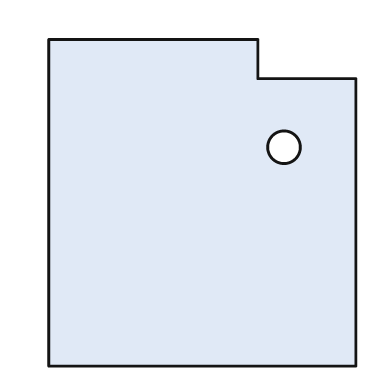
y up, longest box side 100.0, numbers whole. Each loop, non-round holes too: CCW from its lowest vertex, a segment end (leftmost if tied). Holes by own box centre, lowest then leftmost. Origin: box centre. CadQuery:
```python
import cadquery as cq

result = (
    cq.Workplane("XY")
    .moveTo(-47.0, -50.0)
    .lineTo(47.0, -50.0)
    .lineTo(47.0, 38.0)
    .lineTo(17.0, 38.0)
    .lineTo(17.0, 50.0)
    .lineTo(-47.0, 50.0)
    .close()
    .moveTo(25.0, 17.0)
    .circle(5.0)
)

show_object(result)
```